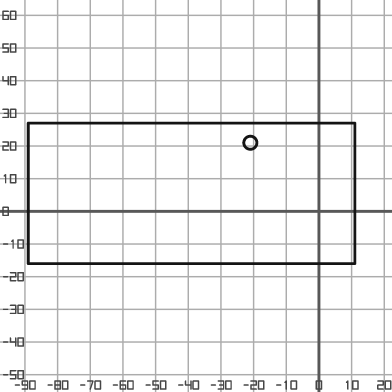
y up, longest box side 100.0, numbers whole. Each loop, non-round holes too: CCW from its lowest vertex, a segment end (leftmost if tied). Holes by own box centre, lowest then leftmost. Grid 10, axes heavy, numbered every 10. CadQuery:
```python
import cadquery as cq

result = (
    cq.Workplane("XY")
    .moveTo(-89.0, -16.0)
    .lineTo(11.0, -16.0)
    .lineTo(11.0, 27.0)
    .lineTo(-89.0, 27.0)
    .close()
    .moveTo(-21.0, 21.0)
    .circle(2.0)
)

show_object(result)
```